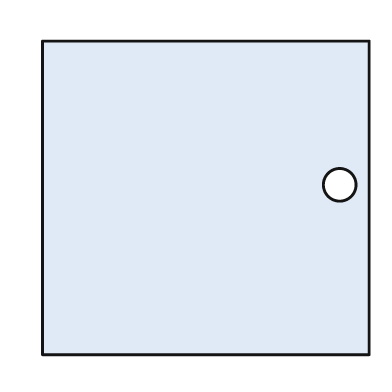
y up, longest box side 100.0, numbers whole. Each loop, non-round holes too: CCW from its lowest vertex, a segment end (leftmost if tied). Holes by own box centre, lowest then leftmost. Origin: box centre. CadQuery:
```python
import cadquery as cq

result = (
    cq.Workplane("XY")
    .moveTo(-50.0, -48.0)
    .lineTo(50.0, -48.0)
    .lineTo(50.0, 48.0)
    .lineTo(-50.0, 48.0)
    .close()
    .moveTo(41.0, 4.0)
    .circle(5.0)
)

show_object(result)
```